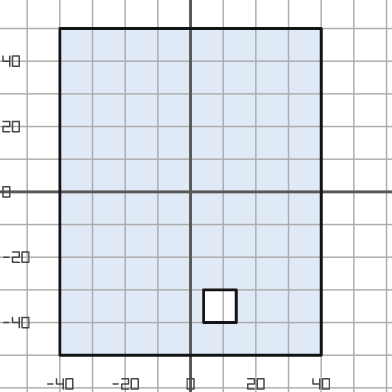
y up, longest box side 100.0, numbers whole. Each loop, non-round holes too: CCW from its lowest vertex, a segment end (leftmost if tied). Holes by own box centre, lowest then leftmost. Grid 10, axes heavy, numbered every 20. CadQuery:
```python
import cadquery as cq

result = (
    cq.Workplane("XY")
    .moveTo(-40.0, -50.0)
    .lineTo(40.0, -50.0)
    .lineTo(40.0, 50.0)
    .lineTo(-40.0, 50.0)
    .close()
    .moveTo(4.0, -40.0)
    .lineTo(14.0, -40.0)
    .lineTo(14.0, -30.0)
    .lineTo(4.0, -30.0)
    .close()
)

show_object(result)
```